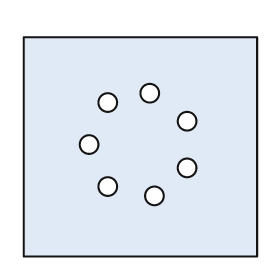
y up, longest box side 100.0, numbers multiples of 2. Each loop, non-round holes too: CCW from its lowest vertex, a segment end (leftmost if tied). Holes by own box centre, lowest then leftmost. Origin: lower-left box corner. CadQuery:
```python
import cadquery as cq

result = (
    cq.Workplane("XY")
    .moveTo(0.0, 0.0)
    .lineTo(100.0, 0.0)
    .lineTo(100.0, 94.0)
    .lineTo(0.0, 94.0)
    .close()
    .moveTo(56.0, 26.0)
    .circle(4.0)
    .moveTo(36.0, 30.0)
    .circle(4.0)
    .moveTo(70.0, 38.0)
    .circle(4.0)
    .moveTo(28.0, 48.0)
    .circle(4.0)
    .moveTo(70.0, 58.0)
    .circle(4.0)
    .moveTo(36.0, 66.0)
    .circle(4.0)
    .moveTo(54.0, 70.0)
    .circle(4.0)
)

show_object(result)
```